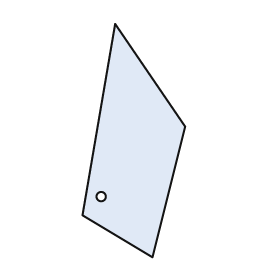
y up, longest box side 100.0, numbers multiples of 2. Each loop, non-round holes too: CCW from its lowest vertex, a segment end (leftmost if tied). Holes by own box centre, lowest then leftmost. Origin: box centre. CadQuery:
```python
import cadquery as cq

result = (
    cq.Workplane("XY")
    .moveTo(8.0, -50.0)
    .lineTo(22.0, 6.0)
    .lineTo(-8.0, 50.0)
    .lineTo(-22.0, -32.0)
    .close()
    .moveTo(-14.0, -24.0)
    .circle(2.0)
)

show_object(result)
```